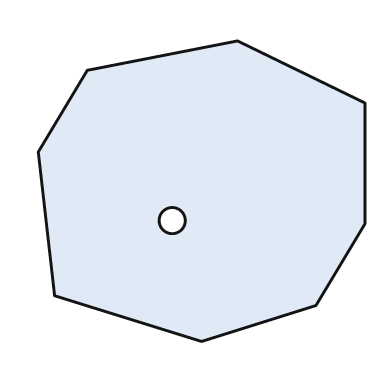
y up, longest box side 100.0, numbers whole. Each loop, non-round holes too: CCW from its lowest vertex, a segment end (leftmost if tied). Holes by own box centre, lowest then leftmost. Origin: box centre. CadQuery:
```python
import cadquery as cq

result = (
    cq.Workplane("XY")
    .moveTo(0.0, -46.0)
    .lineTo(35.0, -35.0)
    .lineTo(50.0, -10.0)
    .lineTo(50.0, 27.0)
    .lineTo(11.0, 46.0)
    .lineTo(-35.0, 37.0)
    .lineTo(-50.0, 12.0)
    .lineTo(-45.0, -32.0)
    .close()
    .moveTo(-9.0, -9.0)
    .circle(4.0)
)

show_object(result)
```